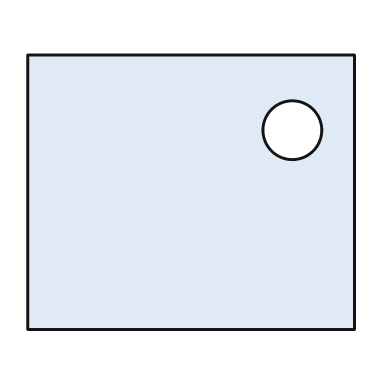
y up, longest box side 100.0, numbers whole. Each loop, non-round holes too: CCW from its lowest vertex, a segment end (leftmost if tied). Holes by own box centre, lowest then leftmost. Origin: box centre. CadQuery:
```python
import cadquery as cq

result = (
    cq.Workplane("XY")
    .moveTo(-50.0, -42.0)
    .lineTo(50.0, -42.0)
    .lineTo(50.0, 42.0)
    .lineTo(-50.0, 42.0)
    .close()
    .moveTo(31.0, 19.0)
    .circle(9.0)
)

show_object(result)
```